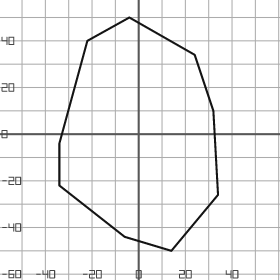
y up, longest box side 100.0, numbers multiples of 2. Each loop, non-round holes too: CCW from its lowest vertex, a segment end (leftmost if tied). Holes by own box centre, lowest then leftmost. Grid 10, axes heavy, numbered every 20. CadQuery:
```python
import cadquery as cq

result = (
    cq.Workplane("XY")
    .moveTo(14.0, -50.0)
    .lineTo(34.0, -26.0)
    .lineTo(32.0, 10.0)
    .lineTo(24.0, 34.0)
    .lineTo(-4.0, 50.0)
    .lineTo(-22.0, 40.0)
    .lineTo(-34.0, -4.0)
    .lineTo(-34.0, -22.0)
    .lineTo(-6.0, -44.0)
    .close()
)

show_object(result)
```